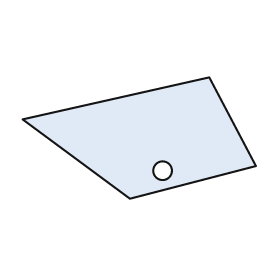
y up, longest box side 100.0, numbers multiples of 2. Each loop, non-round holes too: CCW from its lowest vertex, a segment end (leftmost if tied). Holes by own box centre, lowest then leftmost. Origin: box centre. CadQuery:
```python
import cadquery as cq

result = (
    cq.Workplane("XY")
    .moveTo(-4.0, -26.0)
    .lineTo(50.0, -12.0)
    .lineTo(30.0, 26.0)
    .lineTo(-50.0, 8.0)
    .close()
    .moveTo(10.0, -14.0)
    .circle(4.0)
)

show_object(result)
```